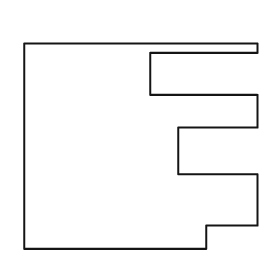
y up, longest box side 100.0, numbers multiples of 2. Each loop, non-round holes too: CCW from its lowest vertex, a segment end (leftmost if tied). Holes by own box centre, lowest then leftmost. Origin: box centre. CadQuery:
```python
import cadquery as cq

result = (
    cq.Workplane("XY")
    .moveTo(-50.0, -44.0)
    .lineTo(28.0, -44.0)
    .lineTo(28.0, -34.0)
    .lineTo(50.0, -34.0)
    .lineTo(50.0, -12.0)
    .lineTo(16.0, -12.0)
    .lineTo(16.0, 8.0)
    .lineTo(50.0, 8.0)
    .lineTo(50.0, 22.0)
    .lineTo(4.0, 22.0)
    .lineTo(4.0, 40.0)
    .lineTo(50.0, 40.0)
    .lineTo(50.0, 44.0)
    .lineTo(-50.0, 44.0)
    .close()
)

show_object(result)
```